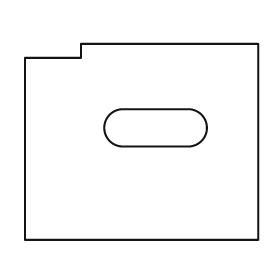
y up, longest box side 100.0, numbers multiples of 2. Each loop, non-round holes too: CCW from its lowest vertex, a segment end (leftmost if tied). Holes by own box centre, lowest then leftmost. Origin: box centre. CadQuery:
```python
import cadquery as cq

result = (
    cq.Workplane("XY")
    .moveTo(-50.0, -42.0)
    .lineTo(50.0, -42.0)
    .lineTo(50.0, 42.0)
    .lineTo(-26.0, 42.0)
    .lineTo(-26.0, 36.0)
    .lineTo(-50.0, 36.0)
    .close()
    .moveTo(-8.0, -2.0)
    .lineTo(20.0, -2.0)
    .threePointArc((28.0, 6.0), (20.0, 14.0))
    .lineTo(-8.0, 14.0)
    .threePointArc((-16.0, 6.0), (-8.0, -2.0))
    .close()
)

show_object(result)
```